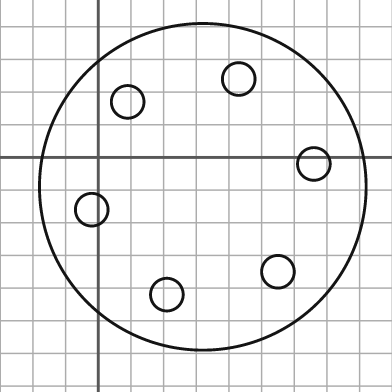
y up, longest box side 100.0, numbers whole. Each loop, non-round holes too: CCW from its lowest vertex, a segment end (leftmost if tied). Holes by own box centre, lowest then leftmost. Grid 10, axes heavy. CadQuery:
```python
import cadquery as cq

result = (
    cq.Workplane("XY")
    .moveTo(32.0, -9.0)
    .circle(50.0)
    .moveTo(21.0, -42.0)
    .circle(5.0)
    .moveTo(55.0, -35.0)
    .circle(5.0)
    .moveTo(-2.0, -16.0)
    .circle(5.0)
    .moveTo(66.0, -2.0)
    .circle(5.0)
    .moveTo(9.0, 17.0)
    .circle(5.0)
    .moveTo(43.0, 24.0)
    .circle(5.0)
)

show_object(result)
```